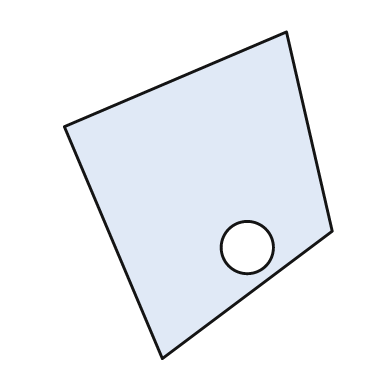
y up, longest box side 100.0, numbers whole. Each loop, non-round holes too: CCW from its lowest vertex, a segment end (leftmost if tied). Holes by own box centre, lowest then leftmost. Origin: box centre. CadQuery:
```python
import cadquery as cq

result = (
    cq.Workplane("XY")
    .moveTo(-11.0, -50.0)
    .lineTo(41.0, -11.0)
    .lineTo(27.0, 50.0)
    .lineTo(-41.0, 21.0)
    .close()
    .moveTo(15.0, -16.0)
    .circle(8.0)
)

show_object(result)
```